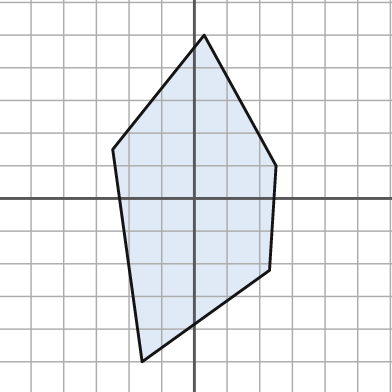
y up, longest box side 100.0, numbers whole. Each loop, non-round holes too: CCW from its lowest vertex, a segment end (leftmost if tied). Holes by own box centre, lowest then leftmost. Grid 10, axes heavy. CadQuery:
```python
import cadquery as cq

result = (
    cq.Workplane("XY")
    .moveTo(-16.0, -50.0)
    .lineTo(23.0, -22.0)
    .lineTo(25.0, 10.0)
    .lineTo(3.0, 50.0)
    .lineTo(-25.0, 15.0)
    .close()
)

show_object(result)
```